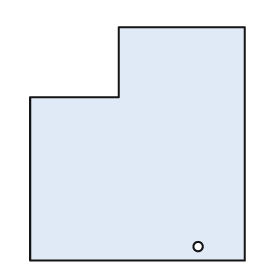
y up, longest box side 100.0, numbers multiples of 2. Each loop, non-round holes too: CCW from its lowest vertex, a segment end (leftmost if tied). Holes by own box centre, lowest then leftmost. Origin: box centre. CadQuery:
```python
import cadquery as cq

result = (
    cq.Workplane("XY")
    .moveTo(-46.0, -50.0)
    .lineTo(46.0, -50.0)
    .lineTo(46.0, 50.0)
    .lineTo(-8.0, 50.0)
    .lineTo(-8.0, 20.0)
    .lineTo(-46.0, 20.0)
    .close()
    .moveTo(26.0, -44.0)
    .circle(2.0)
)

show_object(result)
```